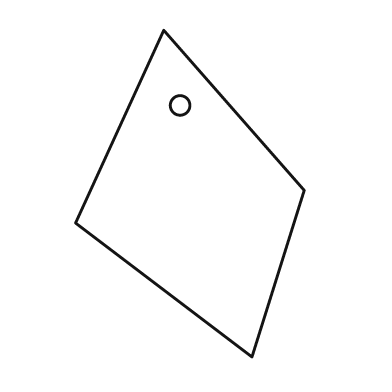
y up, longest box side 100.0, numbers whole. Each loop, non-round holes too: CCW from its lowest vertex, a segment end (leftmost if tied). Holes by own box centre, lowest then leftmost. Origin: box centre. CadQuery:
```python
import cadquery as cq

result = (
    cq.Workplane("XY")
    .moveTo(19.0, -50.0)
    .lineTo(35.0, 1.0)
    .lineTo(-8.0, 50.0)
    .lineTo(-35.0, -9.0)
    .close()
    .moveTo(-3.0, 27.0)
    .circle(3.0)
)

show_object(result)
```